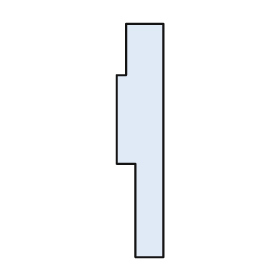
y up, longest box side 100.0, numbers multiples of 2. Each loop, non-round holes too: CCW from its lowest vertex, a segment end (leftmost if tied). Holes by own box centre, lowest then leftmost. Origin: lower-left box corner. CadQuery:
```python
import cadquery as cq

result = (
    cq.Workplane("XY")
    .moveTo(8.0, 0.0)
    .lineTo(20.0, 0.0)
    .lineTo(20.0, 100.0)
    .lineTo(4.0, 100.0)
    .lineTo(4.0, 78.0)
    .lineTo(0.0, 78.0)
    .lineTo(0.0, 40.0)
    .lineTo(8.0, 40.0)
    .close()
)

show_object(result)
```